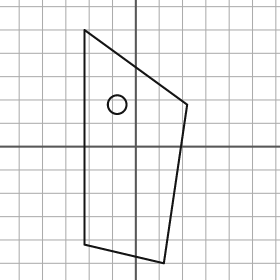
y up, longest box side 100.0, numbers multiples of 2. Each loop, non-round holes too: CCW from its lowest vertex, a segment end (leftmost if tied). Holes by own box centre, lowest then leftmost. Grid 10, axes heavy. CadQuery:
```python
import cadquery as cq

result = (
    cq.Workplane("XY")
    .moveTo(12.0, -50.0)
    .lineTo(22.0, 18.0)
    .lineTo(-22.0, 50.0)
    .lineTo(-22.0, -42.0)
    .close()
    .moveTo(-8.0, 18.0)
    .circle(4.0)
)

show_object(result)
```